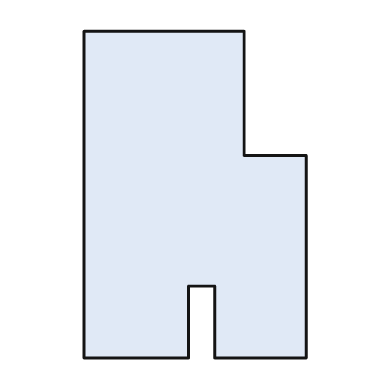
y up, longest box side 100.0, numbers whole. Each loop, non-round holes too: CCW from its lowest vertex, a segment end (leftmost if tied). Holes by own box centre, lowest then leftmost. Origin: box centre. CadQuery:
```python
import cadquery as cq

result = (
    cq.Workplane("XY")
    .moveTo(-34.0, -50.0)
    .lineTo(-2.0, -50.0)
    .lineTo(-2.0, -28.0)
    .lineTo(6.0, -28.0)
    .lineTo(6.0, -50.0)
    .lineTo(34.0, -50.0)
    .lineTo(34.0, 12.0)
    .lineTo(15.0, 12.0)
    .lineTo(15.0, 50.0)
    .lineTo(-34.0, 50.0)
    .close()
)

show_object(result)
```